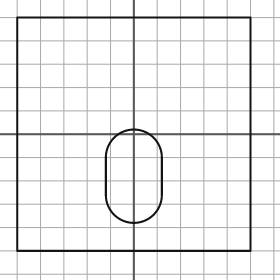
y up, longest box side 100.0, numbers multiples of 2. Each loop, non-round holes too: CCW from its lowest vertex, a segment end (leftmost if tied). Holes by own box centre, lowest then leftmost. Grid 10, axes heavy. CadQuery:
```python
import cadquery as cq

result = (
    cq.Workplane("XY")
    .moveTo(-50.0, -50.0)
    .lineTo(50.0, -50.0)
    .lineTo(50.0, 50.0)
    .lineTo(-50.0, 50.0)
    .close()
    .moveTo(-12.0, -26.0)
    .threePointArc((0.0, -38.0), (12.0, -26.0))
    .lineTo(12.0, -10.0)
    .threePointArc((0.0, 2.0), (-12.0, -10.0))
    .close()
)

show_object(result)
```